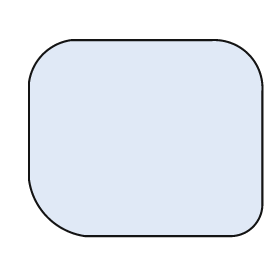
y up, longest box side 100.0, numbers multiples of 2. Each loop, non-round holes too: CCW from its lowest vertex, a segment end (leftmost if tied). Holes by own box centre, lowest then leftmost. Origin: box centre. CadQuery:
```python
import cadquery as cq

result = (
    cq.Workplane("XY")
    .moveTo(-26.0, -42.0)
    .lineTo(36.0, -42.0)
    .threePointArc((46.0, -38.0), (50.0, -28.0))
    .lineTo(50.0, 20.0)
    .threePointArc((44.0, 36.0), (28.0, 42.0))
    .lineTo(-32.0, 42.0)
    .threePointArc((-44.0, 36.0), (-50.0, 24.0))
    .lineTo(-50.0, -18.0)
    .threePointArc((-42.0, -34.0), (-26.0, -42.0))
    .close()
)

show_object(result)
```